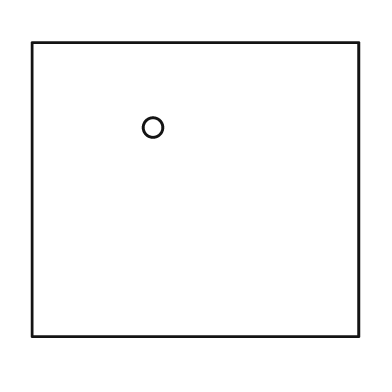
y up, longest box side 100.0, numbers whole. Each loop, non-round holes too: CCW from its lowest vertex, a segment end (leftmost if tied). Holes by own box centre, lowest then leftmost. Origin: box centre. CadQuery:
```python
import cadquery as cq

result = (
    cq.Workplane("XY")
    .moveTo(-50.0, -45.0)
    .lineTo(50.0, -45.0)
    .lineTo(50.0, 45.0)
    .lineTo(-50.0, 45.0)
    .close()
    .moveTo(-13.0, 19.0)
    .circle(3.0)
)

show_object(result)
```